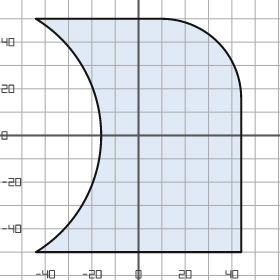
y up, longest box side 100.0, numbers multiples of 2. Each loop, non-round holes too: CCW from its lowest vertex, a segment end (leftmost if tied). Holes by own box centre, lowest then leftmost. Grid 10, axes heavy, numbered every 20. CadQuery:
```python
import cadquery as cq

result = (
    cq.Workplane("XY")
    .moveTo(-44.0, -50.0)
    .lineTo(44.0, -50.0)
    .lineTo(44.0, 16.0)
    .threePointArc((34.0, 40.0), (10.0, 50.0))
    .lineTo(-44.0, 50.0)
    .threePointArc((-16.0, 0.0), (-44.0, -50.0))
    .close()
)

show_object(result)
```